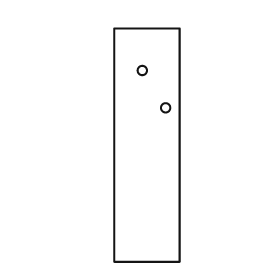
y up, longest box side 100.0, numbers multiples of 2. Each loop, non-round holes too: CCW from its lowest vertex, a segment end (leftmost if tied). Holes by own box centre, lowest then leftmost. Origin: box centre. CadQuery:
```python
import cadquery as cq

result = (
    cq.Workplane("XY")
    .moveTo(-14.0, -50.0)
    .lineTo(14.0, -50.0)
    .lineTo(14.0, 50.0)
    .lineTo(-14.0, 50.0)
    .close()
    .moveTo(8.0, 16.0)
    .circle(2.0)
    .moveTo(-2.0, 32.0)
    .circle(2.0)
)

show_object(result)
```